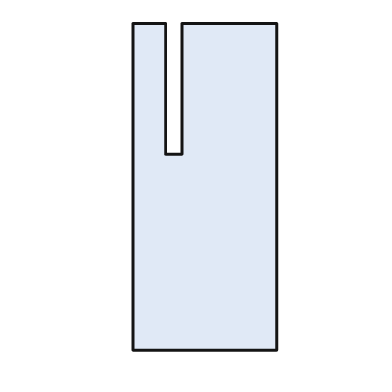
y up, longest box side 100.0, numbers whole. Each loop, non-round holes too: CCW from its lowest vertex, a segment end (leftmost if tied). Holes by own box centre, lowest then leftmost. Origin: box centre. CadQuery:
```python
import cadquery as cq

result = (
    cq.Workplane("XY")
    .moveTo(-22.0, -50.0)
    .lineTo(22.0, -50.0)
    .lineTo(22.0, 50.0)
    .lineTo(-7.0, 50.0)
    .lineTo(-7.0, 10.0)
    .lineTo(-12.0, 10.0)
    .lineTo(-12.0, 50.0)
    .lineTo(-22.0, 50.0)
    .close()
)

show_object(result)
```